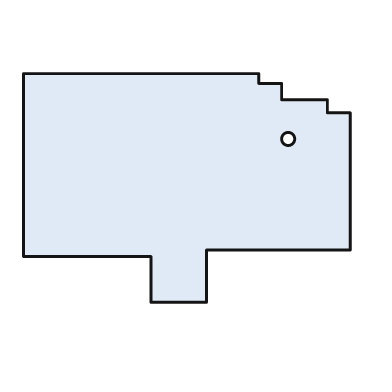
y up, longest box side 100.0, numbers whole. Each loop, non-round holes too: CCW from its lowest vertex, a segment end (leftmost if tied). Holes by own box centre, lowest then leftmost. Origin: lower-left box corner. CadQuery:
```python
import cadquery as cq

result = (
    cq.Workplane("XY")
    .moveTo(39.0, 0.0)
    .lineTo(56.0, 0.0)
    .lineTo(56.0, 16.0)
    .lineTo(100.0, 16.0)
    .lineTo(100.0, 58.0)
    .lineTo(93.0, 58.0)
    .lineTo(93.0, 62.0)
    .lineTo(79.0, 62.0)
    .lineTo(79.0, 67.0)
    .lineTo(72.0, 67.0)
    .lineTo(72.0, 70.0)
    .lineTo(0.0, 70.0)
    .lineTo(0.0, 14.0)
    .lineTo(39.0, 14.0)
    .close()
    .moveTo(81.0, 50.0)
    .circle(2.0)
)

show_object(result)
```